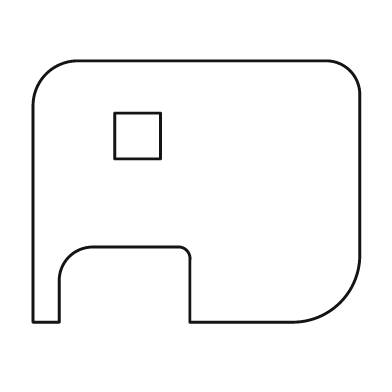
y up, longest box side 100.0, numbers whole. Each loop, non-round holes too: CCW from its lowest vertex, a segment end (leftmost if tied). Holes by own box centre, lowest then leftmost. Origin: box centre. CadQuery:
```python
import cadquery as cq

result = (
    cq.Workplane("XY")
    .moveTo(-50.0, -40.0)
    .lineTo(-42.0, -40.0)
    .lineTo(-42.0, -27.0)
    .threePointArc((-39.0, -20.0), (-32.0, -17.0))
    .lineTo(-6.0, -17.0)
    .threePointArc((-3.0, -18.0), (-2.0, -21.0))
    .lineTo(-2.0, -40.0)
    .lineTo(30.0, -40.0)
    .threePointArc((44.0, -34.0), (50.0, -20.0))
    .lineTo(50.0, 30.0)
    .threePointArc((47.0, 37.0), (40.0, 40.0))
    .lineTo(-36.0, 40.0)
    .threePointArc((-46.0, 36.0), (-50.0, 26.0))
    .close()
    .moveTo(-25.0, 10.0)
    .lineTo(-11.0, 10.0)
    .lineTo(-11.0, 24.0)
    .lineTo(-25.0, 24.0)
    .close()
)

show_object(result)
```